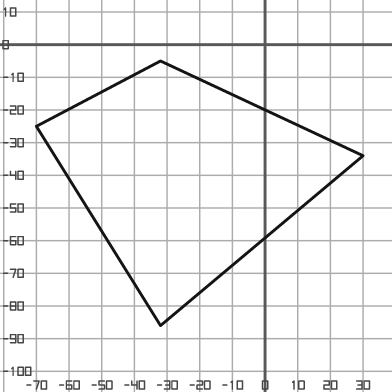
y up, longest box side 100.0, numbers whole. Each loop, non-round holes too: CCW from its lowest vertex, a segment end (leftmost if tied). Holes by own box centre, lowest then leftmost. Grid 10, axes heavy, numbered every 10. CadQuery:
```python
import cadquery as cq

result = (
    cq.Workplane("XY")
    .moveTo(-32.0, -86.0)
    .lineTo(30.0, -34.0)
    .lineTo(-32.0, -5.0)
    .lineTo(-70.0, -25.0)
    .close()
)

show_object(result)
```